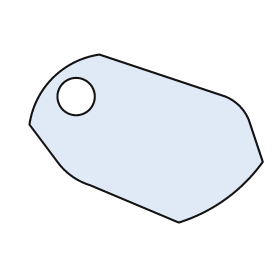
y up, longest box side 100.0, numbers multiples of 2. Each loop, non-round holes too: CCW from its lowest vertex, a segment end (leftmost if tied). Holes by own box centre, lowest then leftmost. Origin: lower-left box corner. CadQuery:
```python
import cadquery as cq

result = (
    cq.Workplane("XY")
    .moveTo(64.0, 0.0)
    .threePointArc((84.0, 10.0), (100.0, 26.0))
    .lineTo(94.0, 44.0)
    .threePointArc((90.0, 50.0), (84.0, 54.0))
    .lineTo(30.0, 72.0)
    .threePointArc((10.0, 62.0), (0.0, 42.0))
    .lineTo(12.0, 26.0)
    .threePointArc((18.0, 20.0), (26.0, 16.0))
    .close()
    .moveTo(20.0, 54.0)
    .circle(8.0)
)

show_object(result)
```